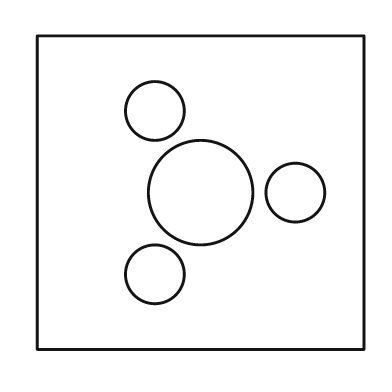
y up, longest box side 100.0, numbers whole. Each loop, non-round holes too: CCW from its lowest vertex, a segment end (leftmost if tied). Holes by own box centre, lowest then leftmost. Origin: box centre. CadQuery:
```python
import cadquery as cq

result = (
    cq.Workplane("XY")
    .moveTo(-50.0, -48.0)
    .lineTo(50.0, -48.0)
    .lineTo(50.0, 48.0)
    .lineTo(-50.0, 48.0)
    .close()
    .moveTo(-14.0, -25.0)
    .circle(9.0)
    .moveTo(0.0, 0.0)
    .circle(16.0)
    .moveTo(29.0, 0.0)
    .circle(9.0)
    .moveTo(-14.0, 25.0)
    .circle(9.0)
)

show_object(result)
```